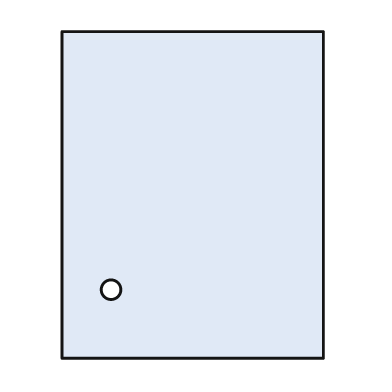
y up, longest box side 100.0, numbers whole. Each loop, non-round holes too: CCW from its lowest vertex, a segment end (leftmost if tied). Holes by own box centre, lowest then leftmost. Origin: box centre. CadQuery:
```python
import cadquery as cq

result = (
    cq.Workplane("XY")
    .moveTo(-40.0, -50.0)
    .lineTo(40.0, -50.0)
    .lineTo(40.0, 50.0)
    .lineTo(-40.0, 50.0)
    .close()
    .moveTo(-25.0, -29.0)
    .circle(3.0)
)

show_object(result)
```